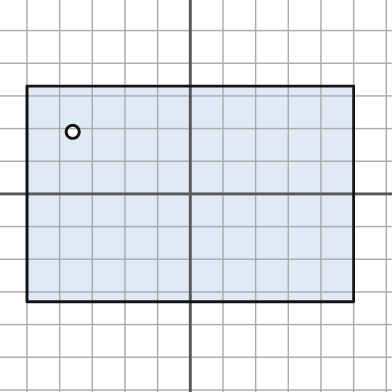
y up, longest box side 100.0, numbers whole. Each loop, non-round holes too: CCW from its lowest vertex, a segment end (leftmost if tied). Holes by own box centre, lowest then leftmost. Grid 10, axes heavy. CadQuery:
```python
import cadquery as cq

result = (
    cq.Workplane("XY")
    .moveTo(-50.0, -33.0)
    .lineTo(50.0, -33.0)
    .lineTo(50.0, 33.0)
    .lineTo(-50.0, 33.0)
    .close()
    .moveTo(-36.0, 19.0)
    .circle(2.0)
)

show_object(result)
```